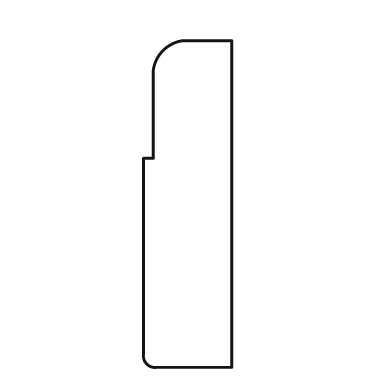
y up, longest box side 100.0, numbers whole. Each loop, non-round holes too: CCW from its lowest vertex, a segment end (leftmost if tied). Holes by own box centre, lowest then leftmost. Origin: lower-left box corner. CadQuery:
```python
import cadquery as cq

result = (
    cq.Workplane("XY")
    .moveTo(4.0, 0.0)
    .lineTo(27.0, 0.0)
    .lineTo(27.0, 100.0)
    .lineTo(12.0, 100.0)
    .threePointArc((6.0, 97.0), (3.0, 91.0))
    .lineTo(3.0, 64.0)
    .lineTo(0.0, 64.0)
    .lineTo(0.0, 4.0)
    .threePointArc((1.0, 1.0), (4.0, 0.0))
    .close()
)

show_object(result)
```